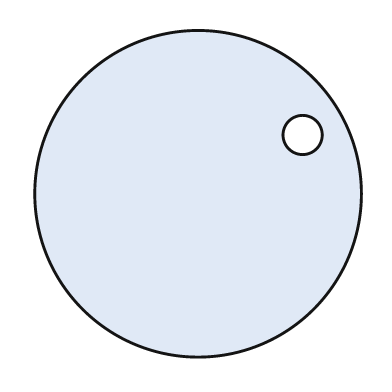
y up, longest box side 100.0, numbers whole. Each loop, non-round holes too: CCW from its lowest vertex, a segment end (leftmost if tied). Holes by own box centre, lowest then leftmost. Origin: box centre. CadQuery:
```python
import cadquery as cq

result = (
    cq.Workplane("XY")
    .moveTo(0.0, 0.0)
    .circle(50.0)
    .moveTo(32.0, 18.0)
    .circle(6.0)
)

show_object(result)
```